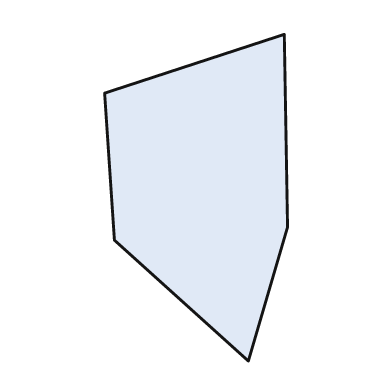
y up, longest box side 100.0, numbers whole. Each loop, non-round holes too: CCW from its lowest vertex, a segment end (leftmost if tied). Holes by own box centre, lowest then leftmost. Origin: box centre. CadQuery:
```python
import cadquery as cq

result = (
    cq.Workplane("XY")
    .moveTo(16.0, -50.0)
    .lineTo(28.0, -9.0)
    .lineTo(27.0, 50.0)
    .lineTo(-28.0, 32.0)
    .lineTo(-25.0, -13.0)
    .close()
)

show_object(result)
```